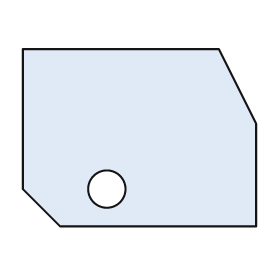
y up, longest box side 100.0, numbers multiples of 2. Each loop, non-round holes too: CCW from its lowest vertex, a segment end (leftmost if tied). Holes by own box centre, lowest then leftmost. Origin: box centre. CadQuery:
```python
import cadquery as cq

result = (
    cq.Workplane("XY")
    .moveTo(-34.0, -38.0)
    .lineTo(50.0, -38.0)
    .lineTo(50.0, 6.0)
    .lineTo(34.0, 38.0)
    .lineTo(-50.0, 38.0)
    .lineTo(-50.0, -22.0)
    .close()
    .moveTo(-14.0, -22.0)
    .circle(8.0)
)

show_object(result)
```